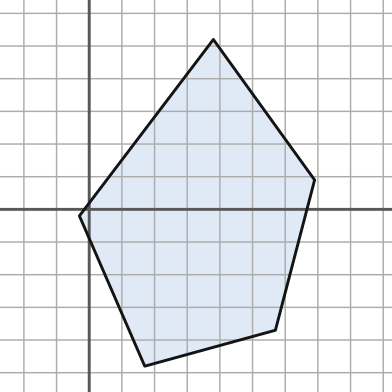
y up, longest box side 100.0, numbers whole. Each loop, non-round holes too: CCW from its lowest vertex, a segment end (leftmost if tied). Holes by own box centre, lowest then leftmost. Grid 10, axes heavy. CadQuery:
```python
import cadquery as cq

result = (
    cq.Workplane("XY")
    .moveTo(17.0, -48.0)
    .lineTo(57.0, -37.0)
    .lineTo(69.0, 9.0)
    .lineTo(38.0, 52.0)
    .lineTo(-3.0, -2.0)
    .close()
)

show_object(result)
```